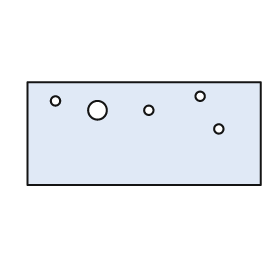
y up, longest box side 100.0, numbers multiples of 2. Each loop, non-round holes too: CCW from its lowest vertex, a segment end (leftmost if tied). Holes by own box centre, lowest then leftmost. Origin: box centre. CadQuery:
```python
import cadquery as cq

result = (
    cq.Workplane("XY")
    .moveTo(-50.0, -22.0)
    .lineTo(50.0, -22.0)
    .lineTo(50.0, 22.0)
    .lineTo(-50.0, 22.0)
    .close()
    .moveTo(32.0, 2.0)
    .circle(2.0)
    .moveTo(-20.0, 10.0)
    .circle(4.0)
    .moveTo(2.0, 10.0)
    .circle(2.0)
    .moveTo(-38.0, 14.0)
    .circle(2.0)
    .moveTo(24.0, 16.0)
    .circle(2.0)
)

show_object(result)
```